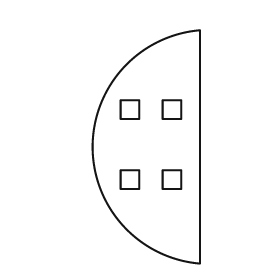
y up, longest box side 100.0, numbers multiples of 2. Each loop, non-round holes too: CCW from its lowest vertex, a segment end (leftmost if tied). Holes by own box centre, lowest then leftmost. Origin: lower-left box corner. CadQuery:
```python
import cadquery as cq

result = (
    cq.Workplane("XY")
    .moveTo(46.0, 0.0)
    .lineTo(46.0, 100.0)
    .threePointArc((0.0, 50.0), (46.0, 0.0))
    .close()
    .moveTo(12.0, 32.0)
    .lineTo(20.0, 32.0)
    .lineTo(20.0, 40.0)
    .lineTo(12.0, 40.0)
    .close()
    .moveTo(30.0, 32.0)
    .lineTo(38.0, 32.0)
    .lineTo(38.0, 40.0)
    .lineTo(30.0, 40.0)
    .close()
    .moveTo(12.0, 62.0)
    .lineTo(20.0, 62.0)
    .lineTo(20.0, 70.0)
    .lineTo(12.0, 70.0)
    .close()
    .moveTo(30.0, 62.0)
    .lineTo(38.0, 62.0)
    .lineTo(38.0, 70.0)
    .lineTo(30.0, 70.0)
    .close()
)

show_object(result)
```